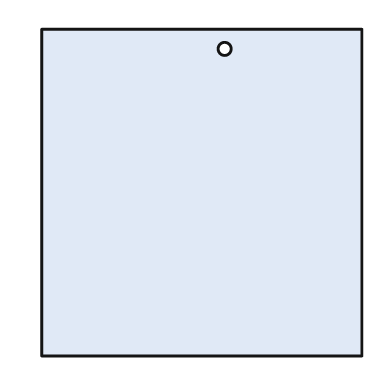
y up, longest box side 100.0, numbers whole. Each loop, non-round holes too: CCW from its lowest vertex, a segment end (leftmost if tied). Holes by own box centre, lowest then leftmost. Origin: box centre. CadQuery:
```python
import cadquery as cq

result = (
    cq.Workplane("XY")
    .moveTo(-49.0, -50.0)
    .lineTo(49.0, -50.0)
    .lineTo(49.0, 50.0)
    .lineTo(-49.0, 50.0)
    .close()
    .moveTo(7.0, 44.0)
    .circle(2.0)
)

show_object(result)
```